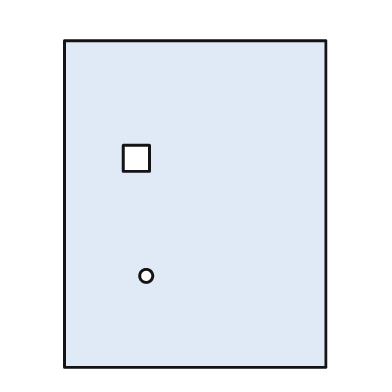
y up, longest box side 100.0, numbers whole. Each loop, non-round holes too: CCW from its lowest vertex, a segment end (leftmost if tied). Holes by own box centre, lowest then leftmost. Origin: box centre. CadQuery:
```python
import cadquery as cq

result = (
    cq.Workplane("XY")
    .moveTo(-40.0, -50.0)
    .lineTo(40.0, -50.0)
    .lineTo(40.0, 50.0)
    .lineTo(-40.0, 50.0)
    .close()
    .moveTo(-15.0, -22.0)
    .circle(2.0)
    .moveTo(-22.0, 10.0)
    .lineTo(-14.0, 10.0)
    .lineTo(-14.0, 18.0)
    .lineTo(-22.0, 18.0)
    .close()
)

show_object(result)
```